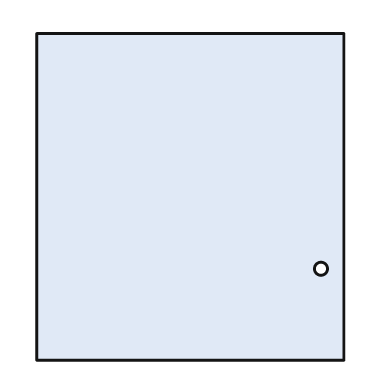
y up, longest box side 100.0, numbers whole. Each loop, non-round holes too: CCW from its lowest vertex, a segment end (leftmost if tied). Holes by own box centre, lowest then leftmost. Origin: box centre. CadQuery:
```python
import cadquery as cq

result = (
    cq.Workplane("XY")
    .moveTo(-47.0, -50.0)
    .lineTo(47.0, -50.0)
    .lineTo(47.0, 50.0)
    .lineTo(-47.0, 50.0)
    .close()
    .moveTo(40.0, -22.0)
    .circle(2.0)
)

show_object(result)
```